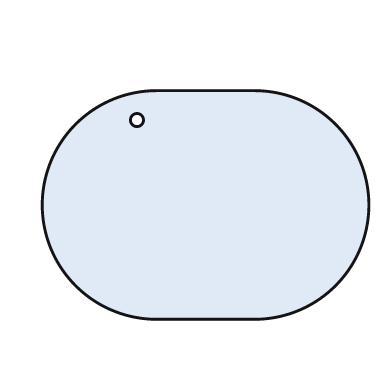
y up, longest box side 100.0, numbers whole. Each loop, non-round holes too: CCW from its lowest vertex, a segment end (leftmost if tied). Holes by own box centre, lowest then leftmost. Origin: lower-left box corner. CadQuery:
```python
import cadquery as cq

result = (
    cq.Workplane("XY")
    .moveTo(35.0, 0.0)
    .lineTo(65.0, 0.0)
    .threePointArc((100.0, 35.0), (65.0, 70.0))
    .lineTo(35.0, 70.0)
    .threePointArc((0.0, 35.0), (35.0, 0.0))
    .close()
    .moveTo(29.0, 61.0)
    .circle(2.0)
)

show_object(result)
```